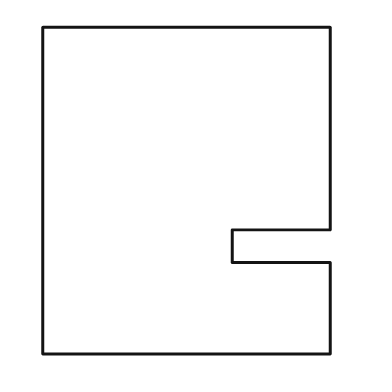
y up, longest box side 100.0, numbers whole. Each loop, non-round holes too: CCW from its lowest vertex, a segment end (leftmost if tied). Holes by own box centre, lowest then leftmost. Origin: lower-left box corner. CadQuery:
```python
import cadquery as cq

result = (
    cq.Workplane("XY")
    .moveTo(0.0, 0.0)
    .lineTo(88.0, 0.0)
    .lineTo(88.0, 28.0)
    .lineTo(58.0, 28.0)
    .lineTo(58.0, 38.0)
    .lineTo(88.0, 38.0)
    .lineTo(88.0, 100.0)
    .lineTo(0.0, 100.0)
    .close()
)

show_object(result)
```